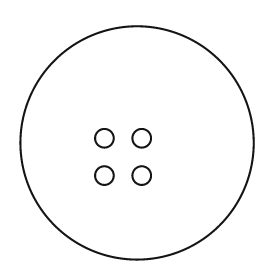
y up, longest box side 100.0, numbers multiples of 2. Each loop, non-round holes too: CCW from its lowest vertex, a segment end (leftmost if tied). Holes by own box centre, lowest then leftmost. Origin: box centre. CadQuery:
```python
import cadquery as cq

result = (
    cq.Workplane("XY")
    .moveTo(0.0, 0.0)
    .circle(50.0)
    .moveTo(-14.0, -14.0)
    .circle(4.0)
    .moveTo(2.0, -14.0)
    .circle(4.0)
    .moveTo(-14.0, 2.0)
    .circle(4.0)
    .moveTo(2.0, 2.0)
    .circle(4.0)
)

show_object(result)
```